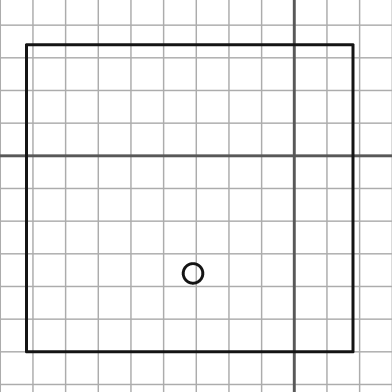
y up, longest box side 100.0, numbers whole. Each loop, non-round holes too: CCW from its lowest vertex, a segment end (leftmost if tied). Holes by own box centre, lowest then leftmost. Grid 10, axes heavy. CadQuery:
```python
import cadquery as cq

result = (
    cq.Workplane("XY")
    .moveTo(-82.0, -60.0)
    .lineTo(18.0, -60.0)
    .lineTo(18.0, 34.0)
    .lineTo(-82.0, 34.0)
    .close()
    .moveTo(-31.0, -36.0)
    .circle(3.0)
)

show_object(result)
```